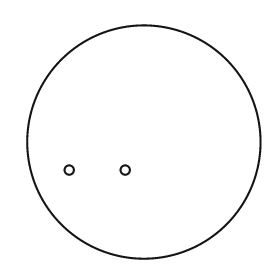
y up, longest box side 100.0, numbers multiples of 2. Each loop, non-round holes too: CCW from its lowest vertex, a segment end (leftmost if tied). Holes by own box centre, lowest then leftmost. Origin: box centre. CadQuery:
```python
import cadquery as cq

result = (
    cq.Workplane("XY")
    .moveTo(0.0, 0.0)
    .circle(50.0)
    .moveTo(-32.0, -12.0)
    .circle(2.0)
    .moveTo(-8.0, -12.0)
    .circle(2.0)
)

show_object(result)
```